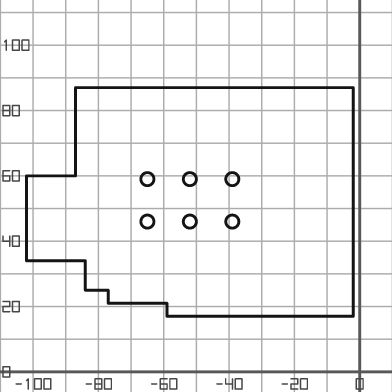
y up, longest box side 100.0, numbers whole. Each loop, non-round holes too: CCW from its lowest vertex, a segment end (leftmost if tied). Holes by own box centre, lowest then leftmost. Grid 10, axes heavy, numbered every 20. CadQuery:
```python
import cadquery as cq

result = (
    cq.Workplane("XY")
    .moveTo(-59.0, 17.0)
    .lineTo(-2.0, 17.0)
    .lineTo(-2.0, 87.0)
    .lineTo(-87.0, 87.0)
    .lineTo(-87.0, 60.0)
    .lineTo(-102.0, 60.0)
    .lineTo(-102.0, 34.0)
    .lineTo(-84.0, 34.0)
    .lineTo(-84.0, 25.0)
    .lineTo(-77.0, 25.0)
    .lineTo(-77.0, 21.0)
    .lineTo(-59.0, 21.0)
    .close()
    .moveTo(-65.0, 46.0)
    .circle(2.0)
    .moveTo(-52.0, 46.0)
    .circle(2.0)
    .moveTo(-39.0, 46.0)
    .circle(2.0)
    .moveTo(-65.0, 59.0)
    .circle(2.0)
    .moveTo(-52.0, 59.0)
    .circle(2.0)
    .moveTo(-39.0, 59.0)
    .circle(2.0)
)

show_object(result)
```